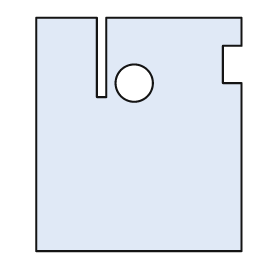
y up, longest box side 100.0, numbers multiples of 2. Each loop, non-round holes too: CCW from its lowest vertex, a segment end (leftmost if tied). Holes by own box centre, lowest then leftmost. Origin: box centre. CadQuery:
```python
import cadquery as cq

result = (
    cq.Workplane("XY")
    .moveTo(-44.0, -50.0)
    .lineTo(44.0, -50.0)
    .lineTo(44.0, 22.0)
    .lineTo(36.0, 22.0)
    .lineTo(36.0, 38.0)
    .lineTo(44.0, 38.0)
    .lineTo(44.0, 50.0)
    .lineTo(-14.0, 50.0)
    .lineTo(-14.0, 16.0)
    .lineTo(-18.0, 16.0)
    .lineTo(-18.0, 50.0)
    .lineTo(-44.0, 50.0)
    .close()
    .moveTo(-2.0, 22.0)
    .circle(8.0)
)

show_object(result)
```